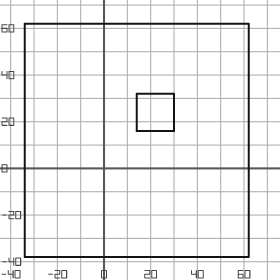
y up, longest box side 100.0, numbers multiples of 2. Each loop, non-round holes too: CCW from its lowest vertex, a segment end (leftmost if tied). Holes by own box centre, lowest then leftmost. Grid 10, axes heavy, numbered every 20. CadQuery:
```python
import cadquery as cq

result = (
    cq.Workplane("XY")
    .moveTo(-34.0, -38.0)
    .lineTo(62.0, -38.0)
    .lineTo(62.0, 62.0)
    .lineTo(-34.0, 62.0)
    .close()
    .moveTo(14.0, 16.0)
    .lineTo(30.0, 16.0)
    .lineTo(30.0, 32.0)
    .lineTo(14.0, 32.0)
    .close()
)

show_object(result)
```